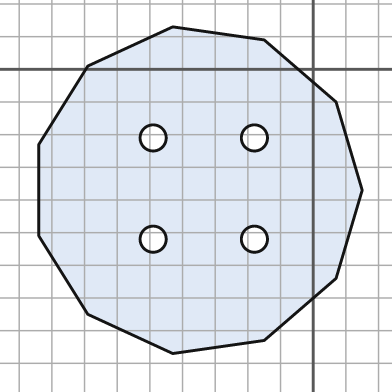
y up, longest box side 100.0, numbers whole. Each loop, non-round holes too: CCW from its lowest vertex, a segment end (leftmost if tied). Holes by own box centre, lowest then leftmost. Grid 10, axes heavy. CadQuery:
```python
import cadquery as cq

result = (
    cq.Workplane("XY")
    .moveTo(-43.0, -87.0)
    .lineTo(-15.0, -83.0)
    .lineTo(7.0, -64.0)
    .lineTo(15.0, -37.0)
    .lineTo(7.0, -10.0)
    .lineTo(-15.0, 9.0)
    .lineTo(-43.0, 13.0)
    .lineTo(-69.0, 1.0)
    .lineTo(-84.0, -23.0)
    .lineTo(-84.0, -51.0)
    .lineTo(-69.0, -75.0)
    .close()
    .moveTo(-49.0, -52.0)
    .circle(4.0)
    .moveTo(-18.0, -52.0)
    .circle(4.0)
    .moveTo(-49.0, -21.0)
    .circle(4.0)
    .moveTo(-18.0, -21.0)
    .circle(4.0)
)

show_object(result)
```